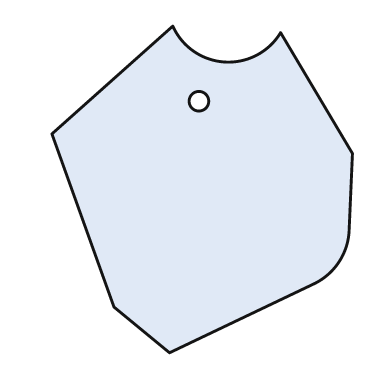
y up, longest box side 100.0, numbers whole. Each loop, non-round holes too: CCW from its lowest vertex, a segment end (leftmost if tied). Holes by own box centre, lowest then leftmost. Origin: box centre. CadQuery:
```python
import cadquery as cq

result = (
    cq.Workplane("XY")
    .moveTo(-10.0, -50.0)
    .lineTo(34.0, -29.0)
    .threePointArc((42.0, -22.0), (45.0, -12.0))
    .lineTo(46.0, 11.0)
    .lineTo(24.0, 48.0)
    .threePointArc((7.0, 39.0), (-9.0, 50.0))
    .lineTo(-46.0, 17.0)
    .lineTo(-27.0, -36.0)
    .close()
    .moveTo(-1.0, 27.0)
    .circle(3.0)
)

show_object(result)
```